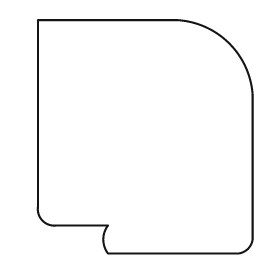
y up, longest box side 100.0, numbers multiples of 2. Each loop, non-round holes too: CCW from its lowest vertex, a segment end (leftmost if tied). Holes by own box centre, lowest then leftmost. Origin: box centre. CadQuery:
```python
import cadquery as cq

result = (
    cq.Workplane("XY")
    .moveTo(-16.0, -50.0)
    .lineTo(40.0, -50.0)
    .threePointArc((44.0, -48.0), (46.0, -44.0))
    .lineTo(46.0, 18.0)
    .threePointArc((36.0, 40.0), (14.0, 50.0))
    .lineTo(-46.0, 50.0)
    .lineTo(-46.0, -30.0)
    .threePointArc((-44.0, -36.0), (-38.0, -38.0))
    .lineTo(-16.0, -38.0)
    .threePointArc((-18.0, -44.0), (-16.0, -50.0))
    .close()
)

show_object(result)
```